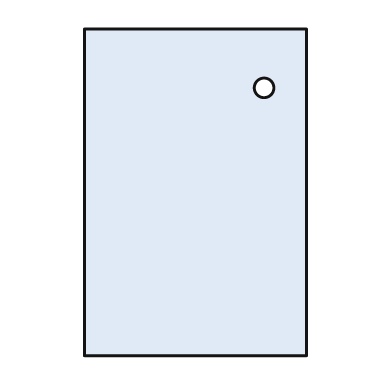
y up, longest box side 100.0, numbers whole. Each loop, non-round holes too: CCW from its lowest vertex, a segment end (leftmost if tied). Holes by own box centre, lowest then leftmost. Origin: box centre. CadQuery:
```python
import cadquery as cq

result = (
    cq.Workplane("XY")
    .moveTo(-34.0, -50.0)
    .lineTo(34.0, -50.0)
    .lineTo(34.0, 50.0)
    .lineTo(-34.0, 50.0)
    .close()
    .moveTo(21.0, 32.0)
    .circle(3.0)
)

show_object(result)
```